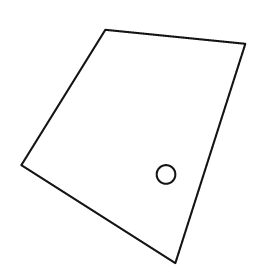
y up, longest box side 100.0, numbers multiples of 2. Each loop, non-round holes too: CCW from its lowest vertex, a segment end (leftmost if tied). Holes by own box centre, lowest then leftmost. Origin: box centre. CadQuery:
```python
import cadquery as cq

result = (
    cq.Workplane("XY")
    .moveTo(18.0, -50.0)
    .lineTo(48.0, 44.0)
    .lineTo(-12.0, 50.0)
    .lineTo(-48.0, -8.0)
    .close()
    .moveTo(14.0, -12.0)
    .circle(4.0)
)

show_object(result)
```